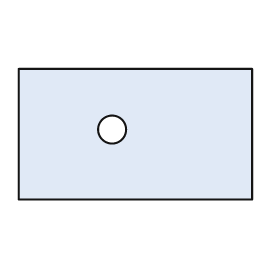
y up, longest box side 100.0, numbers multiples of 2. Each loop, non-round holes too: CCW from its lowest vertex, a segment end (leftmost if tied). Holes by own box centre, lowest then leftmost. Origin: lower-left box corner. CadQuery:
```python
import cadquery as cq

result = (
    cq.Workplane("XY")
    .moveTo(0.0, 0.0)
    .lineTo(100.0, 0.0)
    .lineTo(100.0, 56.0)
    .lineTo(0.0, 56.0)
    .close()
    .moveTo(40.0, 30.0)
    .circle(6.0)
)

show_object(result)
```